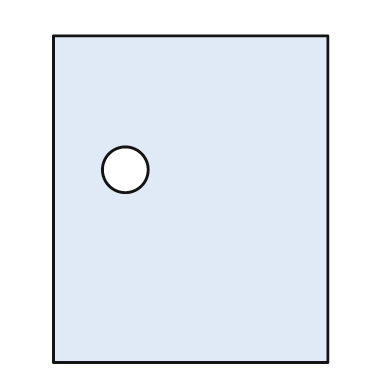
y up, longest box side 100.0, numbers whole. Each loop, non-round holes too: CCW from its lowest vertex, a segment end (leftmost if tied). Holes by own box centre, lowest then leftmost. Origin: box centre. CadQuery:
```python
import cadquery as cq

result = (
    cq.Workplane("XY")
    .moveTo(-42.0, -50.0)
    .lineTo(42.0, -50.0)
    .lineTo(42.0, 50.0)
    .lineTo(-42.0, 50.0)
    .close()
    .moveTo(-20.0, 9.0)
    .circle(7.0)
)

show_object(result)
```